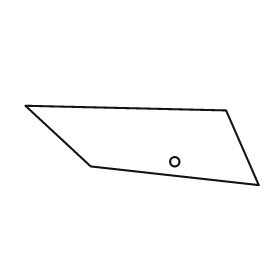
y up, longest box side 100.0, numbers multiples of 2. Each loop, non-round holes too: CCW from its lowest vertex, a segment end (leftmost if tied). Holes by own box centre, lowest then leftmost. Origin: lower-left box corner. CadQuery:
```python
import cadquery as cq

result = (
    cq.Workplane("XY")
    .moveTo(100.0, 0.0)
    .lineTo(86.0, 32.0)
    .lineTo(0.0, 34.0)
    .lineTo(28.0, 8.0)
    .close()
    .moveTo(64.0, 10.0)
    .circle(2.0)
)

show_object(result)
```